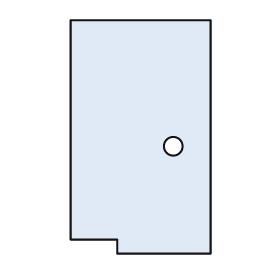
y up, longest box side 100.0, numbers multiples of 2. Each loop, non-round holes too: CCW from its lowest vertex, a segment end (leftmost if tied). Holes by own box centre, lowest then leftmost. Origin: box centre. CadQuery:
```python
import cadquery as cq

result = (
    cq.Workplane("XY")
    .moveTo(-10.0, -50.0)
    .lineTo(30.0, -50.0)
    .lineTo(30.0, 50.0)
    .lineTo(-30.0, 50.0)
    .lineTo(-30.0, -44.0)
    .lineTo(-10.0, -44.0)
    .close()
    .moveTo(14.0, -4.0)
    .circle(4.0)
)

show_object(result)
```